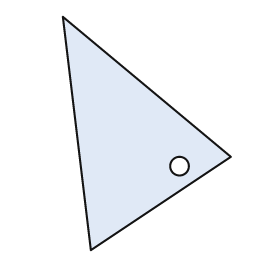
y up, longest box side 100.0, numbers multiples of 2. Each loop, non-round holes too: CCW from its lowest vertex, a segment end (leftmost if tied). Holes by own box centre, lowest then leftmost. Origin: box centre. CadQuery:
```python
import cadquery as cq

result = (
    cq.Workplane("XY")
    .moveTo(-24.0, -50.0)
    .lineTo(36.0, -10.0)
    .lineTo(-36.0, 50.0)
    .close()
    .moveTo(14.0, -14.0)
    .circle(4.0)
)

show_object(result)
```